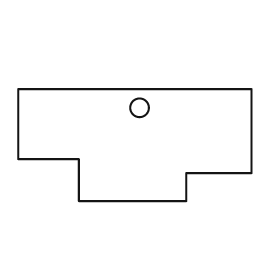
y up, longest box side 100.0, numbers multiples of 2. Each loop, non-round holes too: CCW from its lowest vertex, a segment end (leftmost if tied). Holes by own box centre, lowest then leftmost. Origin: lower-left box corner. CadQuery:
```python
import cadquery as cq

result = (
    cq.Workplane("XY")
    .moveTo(26.0, 0.0)
    .lineTo(72.0, 0.0)
    .lineTo(72.0, 12.0)
    .lineTo(100.0, 12.0)
    .lineTo(100.0, 48.0)
    .lineTo(0.0, 48.0)
    .lineTo(0.0, 18.0)
    .lineTo(26.0, 18.0)
    .close()
    .moveTo(52.0, 40.0)
    .circle(4.0)
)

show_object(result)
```